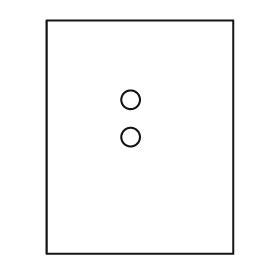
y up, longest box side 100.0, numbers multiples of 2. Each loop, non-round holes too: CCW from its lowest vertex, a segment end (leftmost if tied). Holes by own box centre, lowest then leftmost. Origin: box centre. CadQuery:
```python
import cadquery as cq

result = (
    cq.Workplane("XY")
    .moveTo(-40.0, -50.0)
    .lineTo(40.0, -50.0)
    .lineTo(40.0, 50.0)
    .lineTo(-40.0, 50.0)
    .close()
    .moveTo(-4.0, 0.0)
    .circle(4.0)
    .moveTo(-4.0, 16.0)
    .circle(4.0)
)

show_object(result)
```